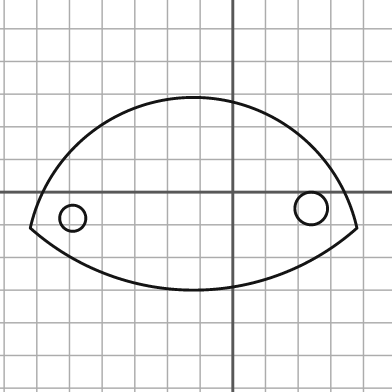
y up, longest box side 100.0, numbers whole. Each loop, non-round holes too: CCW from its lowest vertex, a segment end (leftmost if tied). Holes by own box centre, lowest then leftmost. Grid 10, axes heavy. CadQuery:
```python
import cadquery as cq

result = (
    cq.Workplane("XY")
    .moveTo(-62.0, -11.0)
    .threePointArc((-12.0, -30.0), (38.0, -11.0))
    .threePointArc((-12.0, 29.0), (-62.0, -11.0))
    .close()
    .moveTo(-49.0, -8.0)
    .circle(4.0)
    .moveTo(24.0, -5.0)
    .circle(5.0)
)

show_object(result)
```